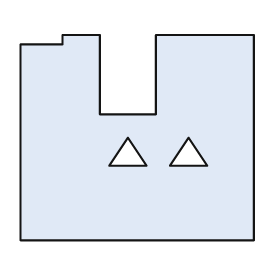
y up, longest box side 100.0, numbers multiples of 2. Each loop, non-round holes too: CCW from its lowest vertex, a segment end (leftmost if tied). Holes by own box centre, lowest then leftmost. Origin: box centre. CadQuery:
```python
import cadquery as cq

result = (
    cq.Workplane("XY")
    .moveTo(-50.0, -44.0)
    .lineTo(50.0, -44.0)
    .lineTo(50.0, 44.0)
    .lineTo(8.0, 44.0)
    .lineTo(8.0, 10.0)
    .lineTo(-16.0, 10.0)
    .lineTo(-16.0, 44.0)
    .lineTo(-32.0, 44.0)
    .lineTo(-32.0, 40.0)
    .lineTo(-50.0, 40.0)
    .close()
    .moveTo(-12.0, -12.0)
    .lineTo(4.0, -12.0)
    .lineTo(-4.0, 0.0)
    .close()
    .moveTo(14.0, -12.0)
    .lineTo(30.0, -12.0)
    .lineTo(22.0, 0.0)
    .close()
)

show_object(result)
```